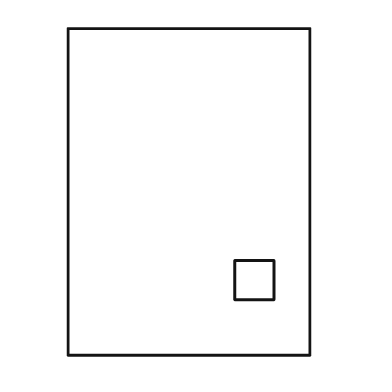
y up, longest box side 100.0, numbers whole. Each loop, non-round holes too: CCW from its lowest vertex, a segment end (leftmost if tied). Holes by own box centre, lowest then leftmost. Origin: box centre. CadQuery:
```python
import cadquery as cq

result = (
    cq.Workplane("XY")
    .moveTo(-37.0, -50.0)
    .lineTo(37.0, -50.0)
    .lineTo(37.0, 50.0)
    .lineTo(-37.0, 50.0)
    .close()
    .moveTo(14.0, -33.0)
    .lineTo(26.0, -33.0)
    .lineTo(26.0, -21.0)
    .lineTo(14.0, -21.0)
    .close()
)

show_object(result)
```